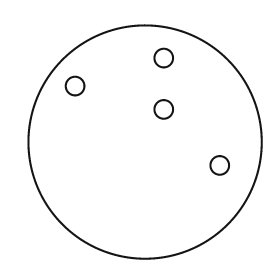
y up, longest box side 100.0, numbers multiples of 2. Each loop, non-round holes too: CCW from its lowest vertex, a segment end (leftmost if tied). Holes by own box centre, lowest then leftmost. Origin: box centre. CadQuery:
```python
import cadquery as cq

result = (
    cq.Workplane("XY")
    .moveTo(0.0, 0.0)
    .circle(50.0)
    .moveTo(32.0, -10.0)
    .circle(4.0)
    .moveTo(8.0, 14.0)
    .circle(4.0)
    .moveTo(-30.0, 24.0)
    .circle(4.0)
    .moveTo(8.0, 36.0)
    .circle(4.0)
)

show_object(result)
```